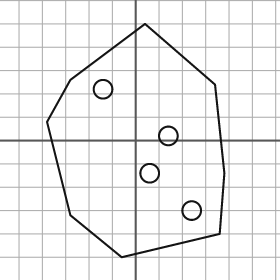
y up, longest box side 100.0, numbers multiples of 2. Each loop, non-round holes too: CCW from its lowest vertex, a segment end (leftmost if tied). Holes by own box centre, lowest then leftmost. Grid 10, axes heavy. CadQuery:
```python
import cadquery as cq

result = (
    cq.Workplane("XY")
    .moveTo(-6.0, -50.0)
    .lineTo(36.0, -40.0)
    .lineTo(38.0, -14.0)
    .lineTo(34.0, 24.0)
    .lineTo(4.0, 50.0)
    .lineTo(-28.0, 26.0)
    .lineTo(-38.0, 8.0)
    .lineTo(-28.0, -32.0)
    .close()
    .moveTo(24.0, -30.0)
    .circle(4.0)
    .moveTo(6.0, -14.0)
    .circle(4.0)
    .moveTo(14.0, 2.0)
    .circle(4.0)
    .moveTo(-14.0, 22.0)
    .circle(4.0)
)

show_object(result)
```